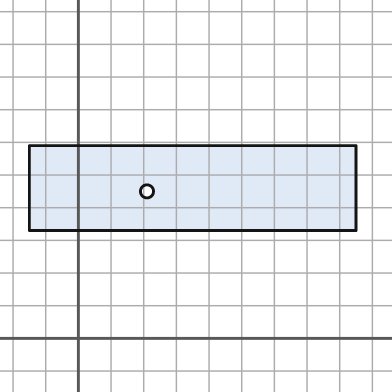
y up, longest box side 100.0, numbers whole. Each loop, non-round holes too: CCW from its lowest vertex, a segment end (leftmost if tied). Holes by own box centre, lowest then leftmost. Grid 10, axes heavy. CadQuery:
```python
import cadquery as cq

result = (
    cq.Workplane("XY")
    .moveTo(-15.0, 33.0)
    .lineTo(85.0, 33.0)
    .lineTo(85.0, 59.0)
    .lineTo(-15.0, 59.0)
    .close()
    .moveTo(21.0, 45.0)
    .circle(2.0)
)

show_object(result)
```